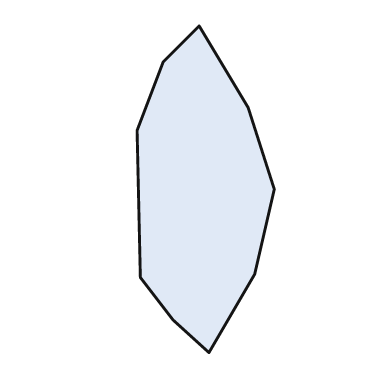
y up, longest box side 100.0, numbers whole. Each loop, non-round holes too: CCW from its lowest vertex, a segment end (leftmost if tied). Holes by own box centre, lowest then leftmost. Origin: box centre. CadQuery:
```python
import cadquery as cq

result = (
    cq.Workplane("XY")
    .moveTo(1.0, -50.0)
    .lineTo(15.0, -26.0)
    .lineTo(21.0, 0.0)
    .lineTo(13.0, 25.0)
    .lineTo(-2.0, 50.0)
    .lineTo(-13.0, 39.0)
    .lineTo(-21.0, 18.0)
    .lineTo(-20.0, -27.0)
    .lineTo(-10.0, -40.0)
    .close()
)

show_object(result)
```